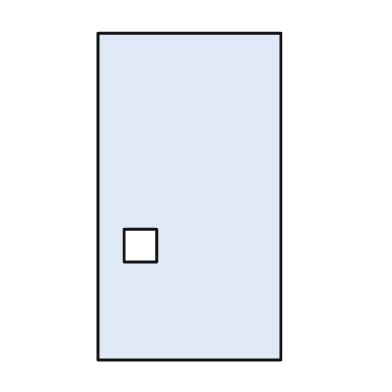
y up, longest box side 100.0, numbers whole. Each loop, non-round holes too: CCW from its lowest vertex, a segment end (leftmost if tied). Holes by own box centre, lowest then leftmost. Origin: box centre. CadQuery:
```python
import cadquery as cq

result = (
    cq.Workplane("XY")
    .moveTo(-28.0, -50.0)
    .lineTo(28.0, -50.0)
    .lineTo(28.0, 50.0)
    .lineTo(-28.0, 50.0)
    .close()
    .moveTo(-20.0, -20.0)
    .lineTo(-10.0, -20.0)
    .lineTo(-10.0, -10.0)
    .lineTo(-20.0, -10.0)
    .close()
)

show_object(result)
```